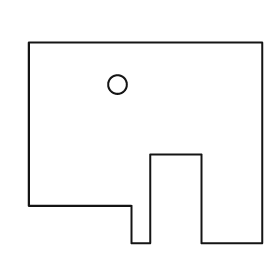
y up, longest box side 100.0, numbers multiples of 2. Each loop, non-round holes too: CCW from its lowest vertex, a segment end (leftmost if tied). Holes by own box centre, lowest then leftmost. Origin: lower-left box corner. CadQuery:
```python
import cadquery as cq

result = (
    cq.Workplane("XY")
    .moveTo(44.0, 0.0)
    .lineTo(52.0, 0.0)
    .lineTo(52.0, 38.0)
    .lineTo(74.0, 38.0)
    .lineTo(74.0, 0.0)
    .lineTo(100.0, 0.0)
    .lineTo(100.0, 86.0)
    .lineTo(0.0, 86.0)
    .lineTo(0.0, 16.0)
    .lineTo(44.0, 16.0)
    .close()
    .moveTo(38.0, 68.0)
    .circle(4.0)
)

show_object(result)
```